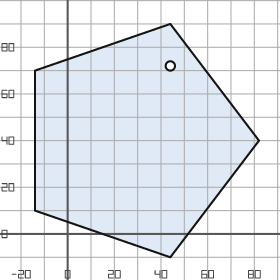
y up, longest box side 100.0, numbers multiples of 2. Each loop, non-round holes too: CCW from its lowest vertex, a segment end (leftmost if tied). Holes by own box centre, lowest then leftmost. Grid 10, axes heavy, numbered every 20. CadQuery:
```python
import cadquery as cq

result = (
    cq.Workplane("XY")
    .moveTo(44.0, -10.0)
    .lineTo(82.0, 40.0)
    .lineTo(44.0, 90.0)
    .lineTo(-14.0, 70.0)
    .lineTo(-14.0, 10.0)
    .close()
    .moveTo(44.0, 72.0)
    .circle(2.0)
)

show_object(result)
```